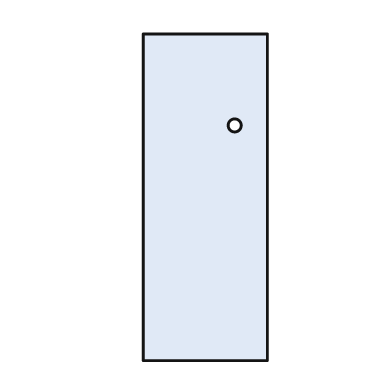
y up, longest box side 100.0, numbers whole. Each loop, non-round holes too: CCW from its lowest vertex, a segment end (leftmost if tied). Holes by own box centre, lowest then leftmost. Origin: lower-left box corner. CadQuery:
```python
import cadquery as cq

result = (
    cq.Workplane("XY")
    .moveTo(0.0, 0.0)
    .lineTo(38.0, 0.0)
    .lineTo(38.0, 100.0)
    .lineTo(0.0, 100.0)
    .close()
    .moveTo(28.0, 72.0)
    .circle(2.0)
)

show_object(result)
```